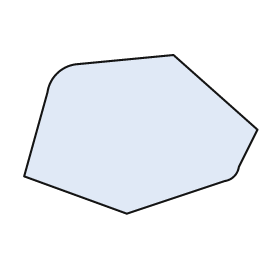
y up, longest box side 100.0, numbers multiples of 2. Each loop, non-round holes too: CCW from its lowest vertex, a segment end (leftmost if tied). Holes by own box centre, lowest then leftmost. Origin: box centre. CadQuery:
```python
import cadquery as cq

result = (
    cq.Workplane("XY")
    .moveTo(-6.0, -34.0)
    .lineTo(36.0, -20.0)
    .threePointArc((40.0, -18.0), (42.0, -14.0))
    .lineTo(50.0, 2.0)
    .lineTo(14.0, 34.0)
    .lineTo(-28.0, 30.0)
    .threePointArc((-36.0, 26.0), (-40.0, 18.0))
    .lineTo(-50.0, -18.0)
    .close()
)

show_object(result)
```